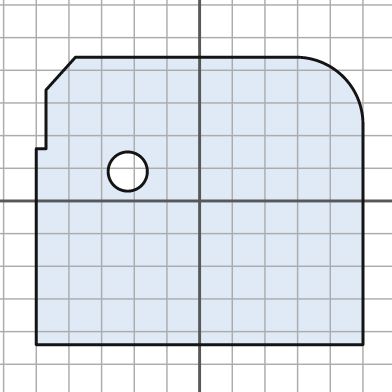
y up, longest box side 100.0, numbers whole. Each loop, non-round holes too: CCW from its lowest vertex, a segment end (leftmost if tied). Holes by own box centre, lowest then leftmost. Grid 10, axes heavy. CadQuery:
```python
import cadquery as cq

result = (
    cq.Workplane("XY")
    .moveTo(-50.0, -44.0)
    .lineTo(50.0, -44.0)
    .lineTo(50.0, 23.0)
    .threePointArc((44.0, 38.0), (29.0, 44.0))
    .lineTo(-38.0, 44.0)
    .lineTo(-47.0, 34.0)
    .lineTo(-47.0, 16.0)
    .lineTo(-50.0, 16.0)
    .close()
    .moveTo(-22.0, 9.0)
    .circle(6.0)
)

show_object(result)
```